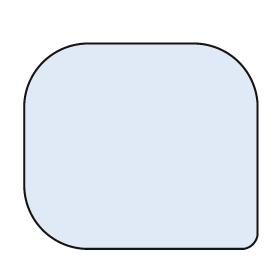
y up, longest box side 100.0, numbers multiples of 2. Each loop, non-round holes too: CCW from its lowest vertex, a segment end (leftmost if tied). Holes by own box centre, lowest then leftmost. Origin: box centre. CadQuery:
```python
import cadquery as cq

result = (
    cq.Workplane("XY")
    .moveTo(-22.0, -44.0)
    .lineTo(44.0, -44.0)
    .threePointArc((48.0, -42.0), (50.0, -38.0))
    .lineTo(50.0, 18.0)
    .threePointArc((42.0, 36.0), (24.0, 44.0))
    .lineTo(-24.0, 44.0)
    .threePointArc((-42.0, 36.0), (-50.0, 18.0))
    .lineTo(-50.0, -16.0)
    .threePointArc((-42.0, -36.0), (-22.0, -44.0))
    .close()
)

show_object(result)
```